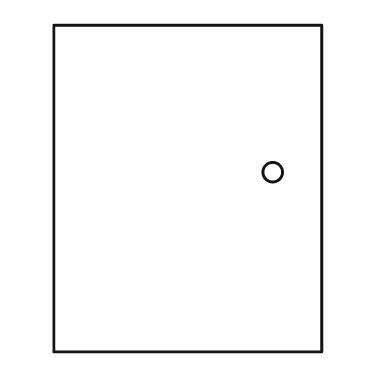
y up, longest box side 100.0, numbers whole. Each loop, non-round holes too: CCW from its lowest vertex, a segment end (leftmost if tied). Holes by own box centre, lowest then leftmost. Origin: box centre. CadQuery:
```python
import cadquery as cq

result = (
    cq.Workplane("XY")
    .moveTo(-41.0, -50.0)
    .lineTo(41.0, -50.0)
    .lineTo(41.0, 50.0)
    .lineTo(-41.0, 50.0)
    .close()
    .moveTo(26.0, 5.0)
    .circle(3.0)
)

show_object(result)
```